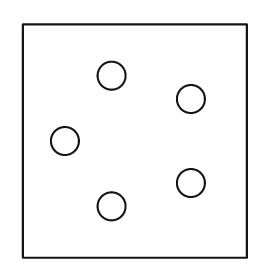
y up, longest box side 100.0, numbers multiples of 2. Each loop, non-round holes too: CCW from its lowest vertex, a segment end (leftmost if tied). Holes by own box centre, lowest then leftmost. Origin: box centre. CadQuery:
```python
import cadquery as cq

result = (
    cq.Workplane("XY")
    .moveTo(-48.0, -50.0)
    .lineTo(48.0, -50.0)
    .lineTo(48.0, 50.0)
    .lineTo(-48.0, 50.0)
    .close()
    .moveTo(-10.0, -28.0)
    .circle(6.0)
    .moveTo(24.0, -18.0)
    .circle(6.0)
    .moveTo(-30.0, 0.0)
    .circle(6.0)
    .moveTo(24.0, 18.0)
    .circle(6.0)
    .moveTo(-10.0, 28.0)
    .circle(6.0)
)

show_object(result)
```